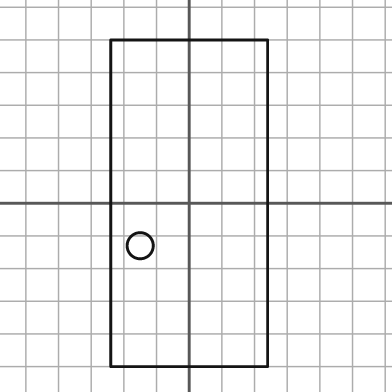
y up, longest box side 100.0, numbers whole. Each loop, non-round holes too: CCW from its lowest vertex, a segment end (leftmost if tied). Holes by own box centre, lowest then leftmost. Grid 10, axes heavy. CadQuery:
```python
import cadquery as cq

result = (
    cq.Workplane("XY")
    .moveTo(-24.0, -50.0)
    .lineTo(24.0, -50.0)
    .lineTo(24.0, 50.0)
    .lineTo(-24.0, 50.0)
    .close()
    .moveTo(-15.0, -13.0)
    .circle(4.0)
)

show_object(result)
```